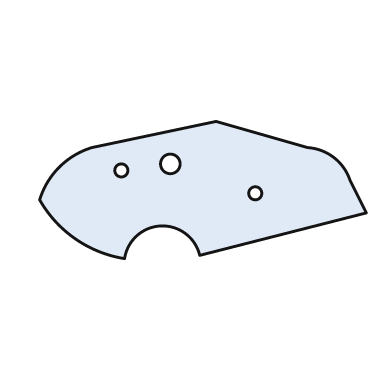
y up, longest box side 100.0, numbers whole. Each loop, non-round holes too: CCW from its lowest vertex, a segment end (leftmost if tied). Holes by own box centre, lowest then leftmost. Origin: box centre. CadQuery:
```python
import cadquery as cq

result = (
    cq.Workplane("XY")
    .moveTo(-24.0, -21.0)
    .threePointArc((-13.0, -11.0), (-1.0, -20.0))
    .lineTo(50.0, -7.0)
    .lineTo(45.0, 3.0)
    .threePointArc((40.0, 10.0), (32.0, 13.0))
    .lineTo(4.0, 21.0)
    .lineTo(-34.0, 13.0)
    .threePointArc((-44.0, 7.0), (-50.0, -3.0))
    .threePointArc((-39.0, -15.0), (-24.0, -21.0))
    .close()
    .moveTo(16.0, -1.0)
    .circle(2.0)
    .moveTo(-25.0, 6.0)
    .circle(2.0)
    .moveTo(-10.0, 8.0)
    .circle(3.0)
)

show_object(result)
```